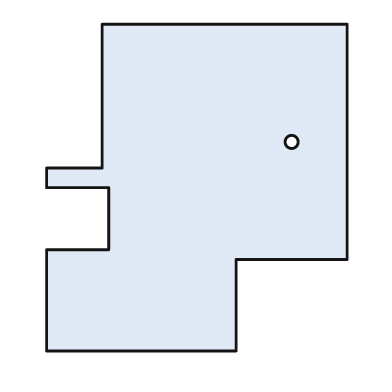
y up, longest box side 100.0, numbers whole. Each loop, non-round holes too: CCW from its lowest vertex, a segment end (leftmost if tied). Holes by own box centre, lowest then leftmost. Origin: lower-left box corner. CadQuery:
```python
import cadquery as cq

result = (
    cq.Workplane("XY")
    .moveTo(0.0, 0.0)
    .lineTo(58.0, 0.0)
    .lineTo(58.0, 28.0)
    .lineTo(92.0, 28.0)
    .lineTo(92.0, 100.0)
    .lineTo(17.0, 100.0)
    .lineTo(17.0, 56.0)
    .lineTo(0.0, 56.0)
    .lineTo(0.0, 50.0)
    .lineTo(19.0, 50.0)
    .lineTo(19.0, 31.0)
    .lineTo(0.0, 31.0)
    .close()
    .moveTo(75.0, 64.0)
    .circle(2.0)
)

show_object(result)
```